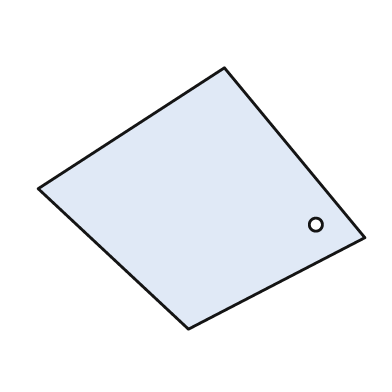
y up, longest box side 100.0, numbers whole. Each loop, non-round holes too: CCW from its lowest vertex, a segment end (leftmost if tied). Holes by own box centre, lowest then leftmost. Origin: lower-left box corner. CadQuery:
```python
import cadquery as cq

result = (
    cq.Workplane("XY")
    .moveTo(46.0, 0.0)
    .lineTo(100.0, 28.0)
    .lineTo(57.0, 80.0)
    .lineTo(0.0, 43.0)
    .close()
    .moveTo(85.0, 32.0)
    .circle(2.0)
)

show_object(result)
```